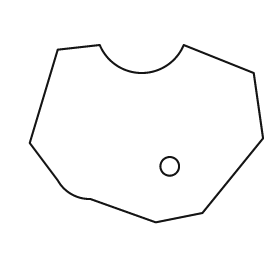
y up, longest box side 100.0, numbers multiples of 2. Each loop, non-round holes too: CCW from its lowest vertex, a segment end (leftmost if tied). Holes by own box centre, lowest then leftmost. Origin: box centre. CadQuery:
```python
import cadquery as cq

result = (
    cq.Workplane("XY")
    .moveTo(4.0, -38.0)
    .lineTo(24.0, -34.0)
    .lineTo(50.0, -2.0)
    .lineTo(46.0, 26.0)
    .lineTo(16.0, 38.0)
    .threePointArc((-2.0, 26.0), (-20.0, 38.0))
    .lineTo(-38.0, 36.0)
    .lineTo(-50.0, -4.0)
    .lineTo(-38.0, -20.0)
    .threePointArc((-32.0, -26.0), (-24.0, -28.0))
    .close()
    .moveTo(10.0, -14.0)
    .circle(4.0)
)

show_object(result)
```